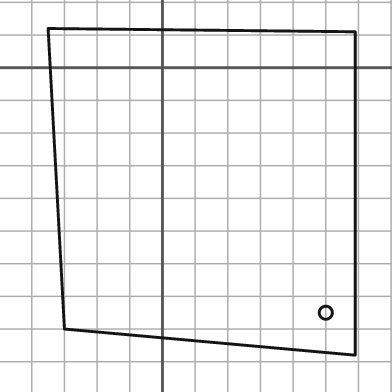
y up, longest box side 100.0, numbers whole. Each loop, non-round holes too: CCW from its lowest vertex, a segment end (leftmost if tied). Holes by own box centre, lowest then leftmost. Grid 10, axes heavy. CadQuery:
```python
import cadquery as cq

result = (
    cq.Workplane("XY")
    .moveTo(59.0, -88.0)
    .lineTo(59.0, 11.0)
    .lineTo(-35.0, 12.0)
    .lineTo(-30.0, -80.0)
    .close()
    .moveTo(50.0, -75.0)
    .circle(2.0)
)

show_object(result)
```